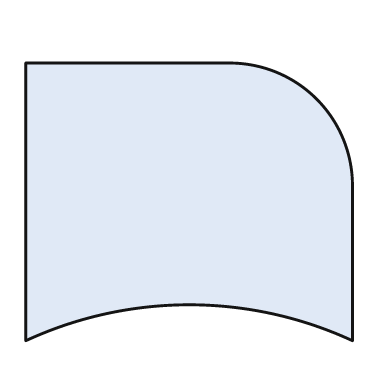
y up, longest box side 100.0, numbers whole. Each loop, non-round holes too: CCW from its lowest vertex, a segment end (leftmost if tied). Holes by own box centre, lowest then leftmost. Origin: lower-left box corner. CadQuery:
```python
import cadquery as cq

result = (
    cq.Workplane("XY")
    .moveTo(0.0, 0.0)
    .threePointArc((50.0, 11.0), (100.0, 0.0))
    .lineTo(100.0, 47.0)
    .threePointArc((89.0, 74.0), (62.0, 85.0))
    .lineTo(0.0, 85.0)
    .close()
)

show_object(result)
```